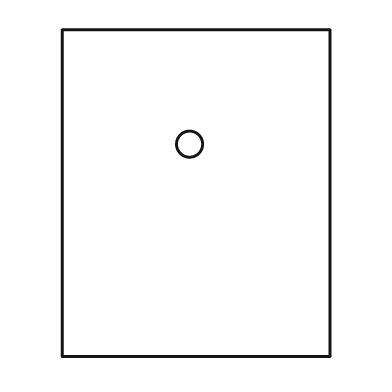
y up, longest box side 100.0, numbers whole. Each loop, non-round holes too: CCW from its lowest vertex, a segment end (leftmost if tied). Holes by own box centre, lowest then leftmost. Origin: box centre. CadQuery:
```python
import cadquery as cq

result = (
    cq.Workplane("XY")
    .moveTo(-41.0, -50.0)
    .lineTo(41.0, -50.0)
    .lineTo(41.0, 50.0)
    .lineTo(-41.0, 50.0)
    .close()
    .moveTo(-2.0, 15.0)
    .circle(4.0)
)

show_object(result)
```